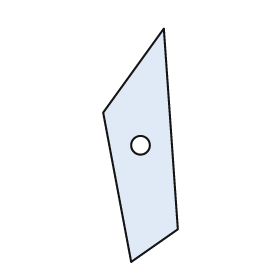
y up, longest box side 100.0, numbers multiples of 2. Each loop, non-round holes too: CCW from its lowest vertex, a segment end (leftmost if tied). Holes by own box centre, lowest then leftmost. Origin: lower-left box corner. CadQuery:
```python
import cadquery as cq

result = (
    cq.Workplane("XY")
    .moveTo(12.0, 0.0)
    .lineTo(32.0, 14.0)
    .lineTo(26.0, 100.0)
    .lineTo(0.0, 64.0)
    .close()
    .moveTo(16.0, 50.0)
    .circle(4.0)
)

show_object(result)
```